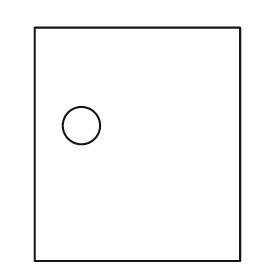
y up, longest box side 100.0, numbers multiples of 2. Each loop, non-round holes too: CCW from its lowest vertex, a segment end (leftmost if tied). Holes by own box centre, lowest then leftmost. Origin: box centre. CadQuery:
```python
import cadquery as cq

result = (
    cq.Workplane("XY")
    .moveTo(-44.0, -50.0)
    .lineTo(44.0, -50.0)
    .lineTo(44.0, 50.0)
    .lineTo(-44.0, 50.0)
    .close()
    .moveTo(-24.0, 8.0)
    .circle(8.0)
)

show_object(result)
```